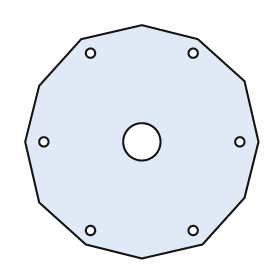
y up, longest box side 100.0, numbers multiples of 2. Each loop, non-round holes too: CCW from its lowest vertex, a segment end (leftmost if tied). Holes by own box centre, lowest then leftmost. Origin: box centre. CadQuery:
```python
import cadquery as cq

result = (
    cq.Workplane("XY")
    .moveTo(0.0, -50.0)
    .lineTo(26.0, -44.0)
    .lineTo(44.0, -24.0)
    .lineTo(50.0, 0.0)
    .lineTo(44.0, 26.0)
    .lineTo(24.0, 44.0)
    .lineTo(0.0, 50.0)
    .lineTo(-26.0, 44.0)
    .lineTo(-44.0, 24.0)
    .lineTo(-50.0, 0.0)
    .lineTo(-44.0, -26.0)
    .lineTo(-24.0, -44.0)
    .close()
    .moveTo(-22.0, -38.0)
    .circle(2.0)
    .moveTo(22.0, -38.0)
    .circle(2.0)
    .moveTo(-42.0, 0.0)
    .circle(2.0)
    .moveTo(0.0, 0.0)
    .circle(8.0)
    .moveTo(42.0, 0.0)
    .circle(2.0)
    .moveTo(-22.0, 38.0)
    .circle(2.0)
    .moveTo(22.0, 38.0)
    .circle(2.0)
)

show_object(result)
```